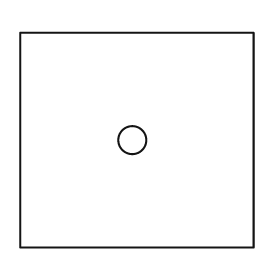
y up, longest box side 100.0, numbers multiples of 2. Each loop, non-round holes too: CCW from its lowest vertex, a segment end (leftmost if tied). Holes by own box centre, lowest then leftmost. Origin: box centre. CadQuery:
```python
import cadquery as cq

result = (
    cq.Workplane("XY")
    .moveTo(-50.0, -46.0)
    .lineTo(50.0, -46.0)
    .lineTo(50.0, 46.0)
    .lineTo(-50.0, 46.0)
    .close()
    .moveTo(-2.0, 0.0)
    .circle(6.0)
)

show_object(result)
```